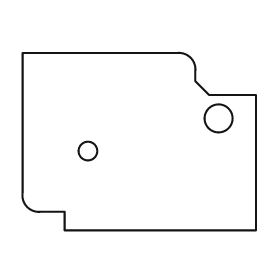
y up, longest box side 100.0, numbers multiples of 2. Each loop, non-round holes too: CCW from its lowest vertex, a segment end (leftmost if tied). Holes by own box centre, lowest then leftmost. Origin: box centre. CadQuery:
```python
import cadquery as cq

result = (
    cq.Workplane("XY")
    .moveTo(-32.0, -38.0)
    .lineTo(50.0, -38.0)
    .lineTo(50.0, 20.0)
    .lineTo(30.0, 20.0)
    .lineTo(24.0, 26.0)
    .lineTo(24.0, 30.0)
    .threePointArc((22.0, 36.0), (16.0, 38.0))
    .lineTo(-50.0, 38.0)
    .lineTo(-50.0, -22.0)
    .threePointArc((-48.0, -28.0), (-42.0, -30.0))
    .lineTo(-32.0, -30.0)
    .close()
    .moveTo(-22.0, -4.0)
    .circle(4.0)
    .moveTo(34.0, 10.0)
    .circle(6.0)
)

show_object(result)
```